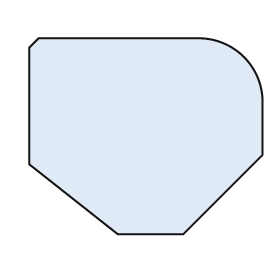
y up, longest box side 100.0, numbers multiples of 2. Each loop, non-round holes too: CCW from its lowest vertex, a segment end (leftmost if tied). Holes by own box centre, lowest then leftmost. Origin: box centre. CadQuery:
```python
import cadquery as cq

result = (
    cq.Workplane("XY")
    .moveTo(-12.0, -42.0)
    .lineTo(16.0, -42.0)
    .lineTo(50.0, -8.0)
    .lineTo(50.0, 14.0)
    .threePointArc((42.0, 34.0), (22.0, 42.0))
    .lineTo(-46.0, 42.0)
    .lineTo(-50.0, 38.0)
    .lineTo(-50.0, -12.0)
    .close()
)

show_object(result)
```